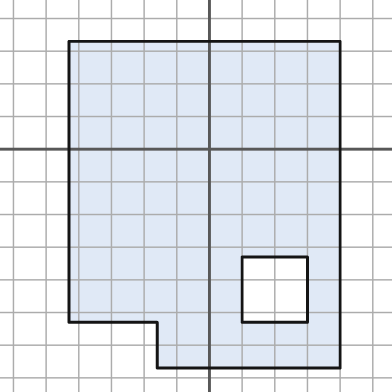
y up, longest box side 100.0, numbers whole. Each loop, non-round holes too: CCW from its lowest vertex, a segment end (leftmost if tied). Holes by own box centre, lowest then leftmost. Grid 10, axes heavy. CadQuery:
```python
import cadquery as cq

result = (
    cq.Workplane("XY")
    .moveTo(-16.0, -67.0)
    .lineTo(40.0, -67.0)
    .lineTo(40.0, 33.0)
    .lineTo(-43.0, 33.0)
    .lineTo(-43.0, -53.0)
    .lineTo(-16.0, -53.0)
    .close()
    .moveTo(10.0, -53.0)
    .lineTo(30.0, -53.0)
    .lineTo(30.0, -33.0)
    .lineTo(10.0, -33.0)
    .close()
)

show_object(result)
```